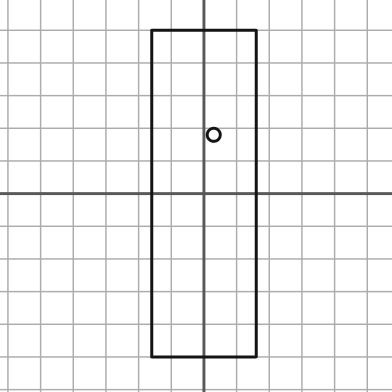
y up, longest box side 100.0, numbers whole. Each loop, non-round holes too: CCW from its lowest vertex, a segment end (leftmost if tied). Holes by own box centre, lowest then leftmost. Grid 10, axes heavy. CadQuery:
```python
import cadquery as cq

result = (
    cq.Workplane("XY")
    .moveTo(-16.0, -50.0)
    .lineTo(16.0, -50.0)
    .lineTo(16.0, 50.0)
    .lineTo(-16.0, 50.0)
    .close()
    .moveTo(3.0, 18.0)
    .circle(2.0)
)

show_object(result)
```